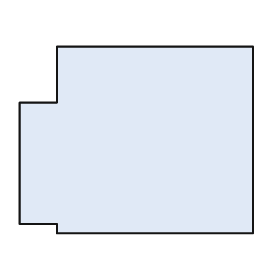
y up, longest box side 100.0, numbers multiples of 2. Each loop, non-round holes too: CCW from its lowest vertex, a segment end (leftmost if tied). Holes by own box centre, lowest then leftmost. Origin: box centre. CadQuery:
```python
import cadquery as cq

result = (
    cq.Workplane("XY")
    .moveTo(-34.0, -40.0)
    .lineTo(50.0, -40.0)
    .lineTo(50.0, 40.0)
    .lineTo(-34.0, 40.0)
    .lineTo(-34.0, 16.0)
    .lineTo(-50.0, 16.0)
    .lineTo(-50.0, -36.0)
    .lineTo(-34.0, -36.0)
    .close()
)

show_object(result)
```